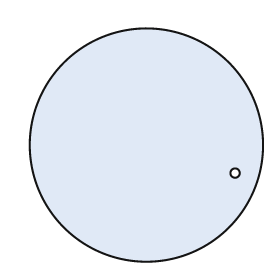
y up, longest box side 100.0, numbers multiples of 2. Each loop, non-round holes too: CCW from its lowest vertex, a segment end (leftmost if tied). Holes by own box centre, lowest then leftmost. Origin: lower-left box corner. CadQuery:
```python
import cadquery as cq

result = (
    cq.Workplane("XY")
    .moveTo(50.0, 50.0)
    .circle(50.0)
    .moveTo(88.0, 38.0)
    .circle(2.0)
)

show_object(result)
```